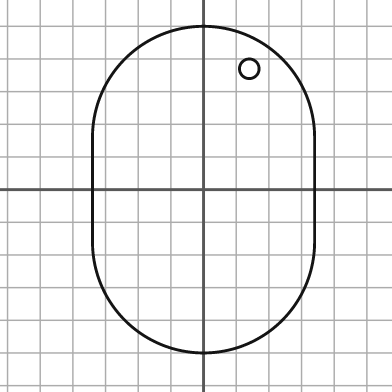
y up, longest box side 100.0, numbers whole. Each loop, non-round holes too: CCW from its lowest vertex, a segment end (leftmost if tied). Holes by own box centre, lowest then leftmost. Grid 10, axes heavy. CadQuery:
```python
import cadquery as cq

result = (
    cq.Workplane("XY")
    .moveTo(-34.0, -16.0)
    .threePointArc((0.0, -50.0), (34.0, -16.0))
    .lineTo(34.0, 16.0)
    .threePointArc((0.0, 50.0), (-34.0, 16.0))
    .close()
    .moveTo(14.0, 37.0)
    .circle(3.0)
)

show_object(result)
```